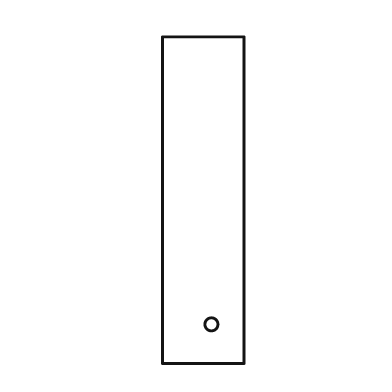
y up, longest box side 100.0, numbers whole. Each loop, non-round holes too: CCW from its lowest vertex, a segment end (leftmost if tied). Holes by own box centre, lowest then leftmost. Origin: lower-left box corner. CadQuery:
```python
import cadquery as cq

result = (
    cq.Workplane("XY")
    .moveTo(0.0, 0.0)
    .lineTo(25.0, 0.0)
    .lineTo(25.0, 100.0)
    .lineTo(0.0, 100.0)
    .close()
    .moveTo(15.0, 12.0)
    .circle(2.0)
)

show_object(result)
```